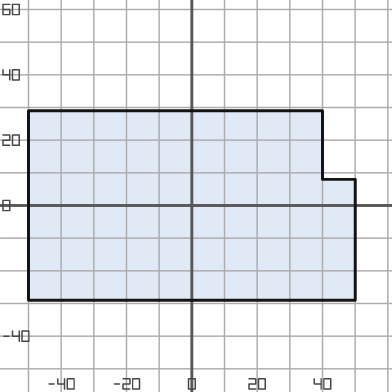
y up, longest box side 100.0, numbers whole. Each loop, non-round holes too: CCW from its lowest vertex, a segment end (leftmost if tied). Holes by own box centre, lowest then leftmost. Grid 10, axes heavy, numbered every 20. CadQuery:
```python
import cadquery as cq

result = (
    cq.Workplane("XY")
    .moveTo(-50.0, -29.0)
    .lineTo(50.0, -29.0)
    .lineTo(50.0, 8.0)
    .lineTo(40.0, 8.0)
    .lineTo(40.0, 29.0)
    .lineTo(-50.0, 29.0)
    .close()
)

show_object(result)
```